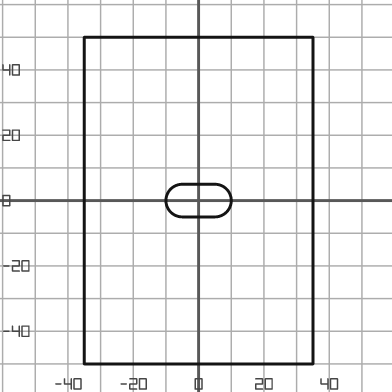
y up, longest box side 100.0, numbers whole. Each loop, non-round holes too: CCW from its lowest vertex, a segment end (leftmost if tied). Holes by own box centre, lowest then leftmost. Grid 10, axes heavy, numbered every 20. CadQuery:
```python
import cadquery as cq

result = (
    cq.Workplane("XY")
    .moveTo(-35.0, -50.0)
    .lineTo(35.0, -50.0)
    .lineTo(35.0, 50.0)
    .lineTo(-35.0, 50.0)
    .close()
    .moveTo(-5.0, -5.0)
    .lineTo(5.0, -5.0)
    .threePointArc((10.0, 0.0), (5.0, 5.0))
    .lineTo(-5.0, 5.0)
    .threePointArc((-10.0, 0.0), (-5.0, -5.0))
    .close()
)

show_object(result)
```